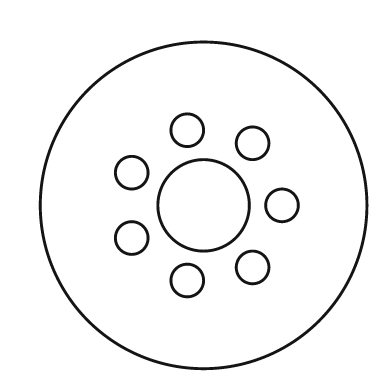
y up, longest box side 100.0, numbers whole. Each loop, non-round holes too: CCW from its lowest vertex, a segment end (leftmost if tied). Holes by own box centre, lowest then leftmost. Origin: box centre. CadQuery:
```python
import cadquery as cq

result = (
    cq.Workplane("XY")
    .moveTo(0.0, 0.0)
    .circle(50.0)
    .moveTo(-5.0, -23.0)
    .circle(5.0)
    .moveTo(15.0, -19.0)
    .circle(5.0)
    .moveTo(-22.0, -10.0)
    .circle(5.0)
    .moveTo(0.0, 0.0)
    .circle(14.0)
    .moveTo(24.0, 0.0)
    .circle(5.0)
    .moveTo(-22.0, 10.0)
    .circle(5.0)
    .moveTo(15.0, 19.0)
    .circle(5.0)
    .moveTo(-5.0, 23.0)
    .circle(5.0)
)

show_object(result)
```